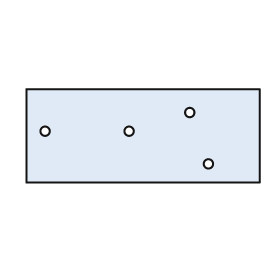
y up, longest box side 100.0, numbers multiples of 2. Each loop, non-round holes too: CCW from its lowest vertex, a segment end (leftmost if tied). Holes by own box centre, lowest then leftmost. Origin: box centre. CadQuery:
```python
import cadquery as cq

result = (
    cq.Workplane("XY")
    .moveTo(-50.0, -20.0)
    .lineTo(50.0, -20.0)
    .lineTo(50.0, 20.0)
    .lineTo(-50.0, 20.0)
    .close()
    .moveTo(28.0, -12.0)
    .circle(2.0)
    .moveTo(-42.0, 2.0)
    .circle(2.0)
    .moveTo(-6.0, 2.0)
    .circle(2.0)
    .moveTo(20.0, 10.0)
    .circle(2.0)
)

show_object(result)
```